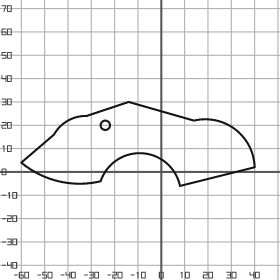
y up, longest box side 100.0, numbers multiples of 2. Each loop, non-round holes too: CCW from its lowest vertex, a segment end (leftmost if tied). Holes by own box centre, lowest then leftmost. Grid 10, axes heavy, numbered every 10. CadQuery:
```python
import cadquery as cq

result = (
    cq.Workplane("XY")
    .moveTo(8.0, -6.0)
    .lineTo(40.0, 2.0)
    .threePointArc((32.0, 18.0), (14.0, 22.0))
    .lineTo(-14.0, 30.0)
    .lineTo(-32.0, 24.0)
    .threePointArc((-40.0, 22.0), (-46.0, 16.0))
    .lineTo(-60.0, 4.0)
    .threePointArc((-44.0, -4.0), (-26.0, -4.0))
    .threePointArc((-8.0, 8.0), (8.0, -6.0))
    .close()
    .moveTo(-24.0, 20.0)
    .circle(2.0)
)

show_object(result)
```